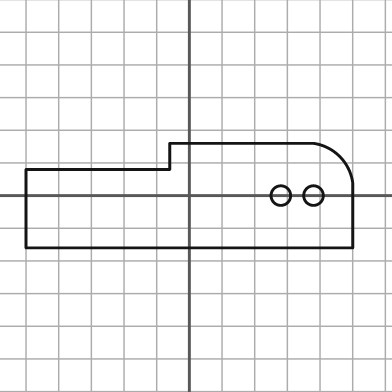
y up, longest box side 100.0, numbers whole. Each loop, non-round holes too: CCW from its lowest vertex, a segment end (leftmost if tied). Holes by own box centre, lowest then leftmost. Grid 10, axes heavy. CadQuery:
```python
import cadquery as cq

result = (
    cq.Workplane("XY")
    .moveTo(-50.0, -16.0)
    .lineTo(50.0, -16.0)
    .lineTo(50.0, 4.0)
    .threePointArc((46.0, 12.0), (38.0, 16.0))
    .lineTo(-6.0, 16.0)
    .lineTo(-6.0, 8.0)
    .lineTo(-50.0, 8.0)
    .close()
    .moveTo(28.0, 0.0)
    .circle(3.0)
    .moveTo(38.0, 0.0)
    .circle(3.0)
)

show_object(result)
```